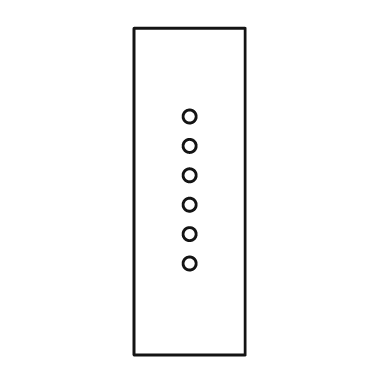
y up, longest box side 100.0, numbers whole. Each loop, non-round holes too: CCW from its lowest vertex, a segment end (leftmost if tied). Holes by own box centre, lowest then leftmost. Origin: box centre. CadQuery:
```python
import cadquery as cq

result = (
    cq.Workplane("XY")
    .moveTo(-17.0, -50.0)
    .lineTo(17.0, -50.0)
    .lineTo(17.0, 50.0)
    .lineTo(-17.0, 50.0)
    .close()
    .moveTo(0.0, -22.0)
    .circle(2.0)
    .moveTo(0.0, -13.0)
    .circle(2.0)
    .moveTo(0.0, -4.0)
    .circle(2.0)
    .moveTo(0.0, 5.0)
    .circle(2.0)
    .moveTo(0.0, 14.0)
    .circle(2.0)
    .moveTo(0.0, 23.0)
    .circle(2.0)
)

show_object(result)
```